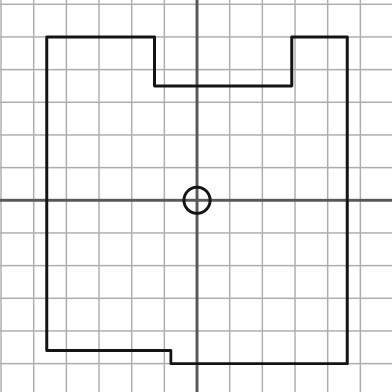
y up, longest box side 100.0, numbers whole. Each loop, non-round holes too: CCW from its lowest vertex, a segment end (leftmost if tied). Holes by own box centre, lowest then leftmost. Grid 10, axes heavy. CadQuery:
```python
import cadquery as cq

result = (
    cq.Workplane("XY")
    .moveTo(-8.0, -50.0)
    .lineTo(46.0, -50.0)
    .lineTo(46.0, 50.0)
    .lineTo(29.0, 50.0)
    .lineTo(29.0, 35.0)
    .lineTo(-13.0, 35.0)
    .lineTo(-13.0, 50.0)
    .lineTo(-46.0, 50.0)
    .lineTo(-46.0, -46.0)
    .lineTo(-8.0, -46.0)
    .close()
    .moveTo(0.0, 0.0)
    .circle(4.0)
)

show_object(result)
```